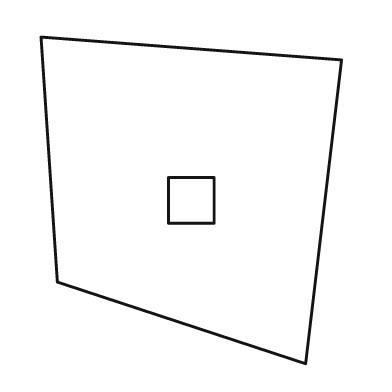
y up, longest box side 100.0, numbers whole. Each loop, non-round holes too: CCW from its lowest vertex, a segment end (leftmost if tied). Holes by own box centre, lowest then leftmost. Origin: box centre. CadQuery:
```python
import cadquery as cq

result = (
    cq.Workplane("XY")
    .moveTo(35.0, -50.0)
    .lineTo(46.0, 43.0)
    .lineTo(-46.0, 50.0)
    .lineTo(-41.0, -25.0)
    .close()
    .moveTo(-7.0, -7.0)
    .lineTo(7.0, -7.0)
    .lineTo(7.0, 7.0)
    .lineTo(-7.0, 7.0)
    .close()
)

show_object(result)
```